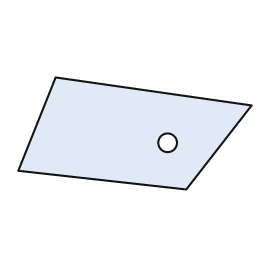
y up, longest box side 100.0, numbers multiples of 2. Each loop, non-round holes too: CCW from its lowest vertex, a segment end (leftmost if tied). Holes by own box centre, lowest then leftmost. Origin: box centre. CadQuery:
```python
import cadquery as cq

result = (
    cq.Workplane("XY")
    .moveTo(22.0, -24.0)
    .lineTo(50.0, 12.0)
    .lineTo(-34.0, 24.0)
    .lineTo(-50.0, -16.0)
    .close()
    .moveTo(14.0, -4.0)
    .circle(4.0)
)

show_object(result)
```